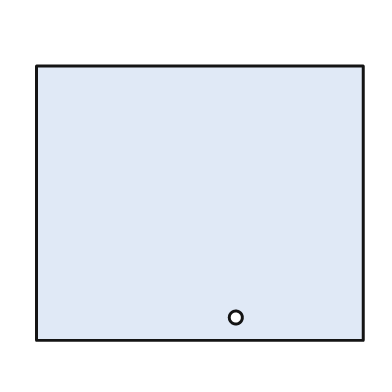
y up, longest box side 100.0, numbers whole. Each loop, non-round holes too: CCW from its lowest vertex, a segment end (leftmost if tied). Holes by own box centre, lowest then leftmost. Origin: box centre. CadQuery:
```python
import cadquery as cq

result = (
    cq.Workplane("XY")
    .moveTo(-50.0, -42.0)
    .lineTo(50.0, -42.0)
    .lineTo(50.0, 42.0)
    .lineTo(-50.0, 42.0)
    .close()
    .moveTo(11.0, -35.0)
    .circle(2.0)
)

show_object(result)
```